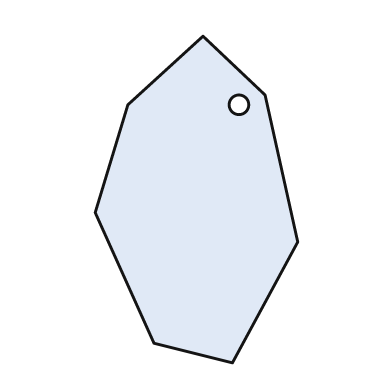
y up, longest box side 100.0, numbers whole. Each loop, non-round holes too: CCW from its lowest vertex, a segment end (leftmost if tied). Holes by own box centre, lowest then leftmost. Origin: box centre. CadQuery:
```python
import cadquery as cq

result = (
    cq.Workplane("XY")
    .moveTo(11.0, -50.0)
    .lineTo(31.0, -13.0)
    .lineTo(21.0, 32.0)
    .lineTo(2.0, 50.0)
    .lineTo(-21.0, 29.0)
    .lineTo(-31.0, -4.0)
    .lineTo(-13.0, -44.0)
    .close()
    .moveTo(13.0, 29.0)
    .circle(3.0)
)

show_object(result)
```